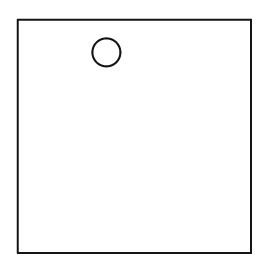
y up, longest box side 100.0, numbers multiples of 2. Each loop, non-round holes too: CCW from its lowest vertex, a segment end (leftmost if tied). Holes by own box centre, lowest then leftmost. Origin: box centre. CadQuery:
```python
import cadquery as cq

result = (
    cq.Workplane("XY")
    .moveTo(-50.0, -50.0)
    .lineTo(50.0, -50.0)
    .lineTo(50.0, 50.0)
    .lineTo(-50.0, 50.0)
    .close()
    .moveTo(-12.0, 36.0)
    .circle(6.0)
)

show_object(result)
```